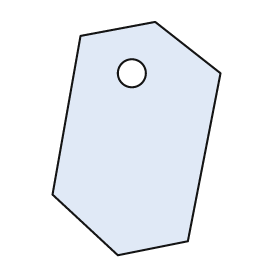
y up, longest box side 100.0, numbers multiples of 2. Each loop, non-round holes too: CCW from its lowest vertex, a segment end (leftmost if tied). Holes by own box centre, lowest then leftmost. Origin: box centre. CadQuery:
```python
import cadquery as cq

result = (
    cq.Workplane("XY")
    .moveTo(-8.0, -50.0)
    .lineTo(22.0, -44.0)
    .lineTo(36.0, 28.0)
    .lineTo(8.0, 50.0)
    .lineTo(-24.0, 44.0)
    .lineTo(-36.0, -24.0)
    .close()
    .moveTo(-2.0, 28.0)
    .circle(6.0)
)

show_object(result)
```